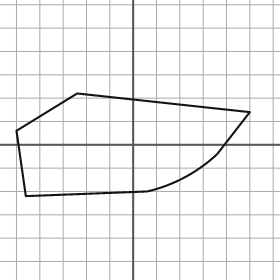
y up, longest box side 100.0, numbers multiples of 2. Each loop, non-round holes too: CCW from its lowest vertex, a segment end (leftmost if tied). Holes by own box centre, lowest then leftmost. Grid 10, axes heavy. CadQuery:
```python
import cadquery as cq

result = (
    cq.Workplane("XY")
    .moveTo(-46.0, -22.0)
    .lineTo(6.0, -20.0)
    .threePointArc((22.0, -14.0), (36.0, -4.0))
    .lineTo(50.0, 14.0)
    .lineTo(-24.0, 22.0)
    .lineTo(-50.0, 6.0)
    .close()
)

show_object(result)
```